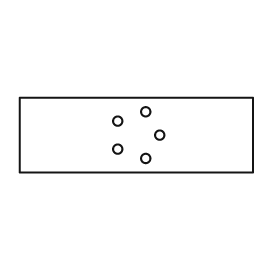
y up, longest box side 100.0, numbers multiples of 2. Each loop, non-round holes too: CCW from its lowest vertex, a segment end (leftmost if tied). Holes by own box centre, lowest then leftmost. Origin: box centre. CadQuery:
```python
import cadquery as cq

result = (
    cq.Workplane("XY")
    .moveTo(-50.0, -16.0)
    .lineTo(50.0, -16.0)
    .lineTo(50.0, 16.0)
    .lineTo(-50.0, 16.0)
    .close()
    .moveTo(4.0, -10.0)
    .circle(2.0)
    .moveTo(-8.0, -6.0)
    .circle(2.0)
    .moveTo(10.0, 0.0)
    .circle(2.0)
    .moveTo(-8.0, 6.0)
    .circle(2.0)
    .moveTo(4.0, 10.0)
    .circle(2.0)
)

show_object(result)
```